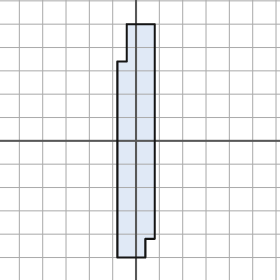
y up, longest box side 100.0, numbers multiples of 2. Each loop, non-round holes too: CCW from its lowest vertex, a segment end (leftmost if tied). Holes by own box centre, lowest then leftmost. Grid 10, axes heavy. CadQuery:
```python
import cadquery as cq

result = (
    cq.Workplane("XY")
    .moveTo(-8.0, -50.0)
    .lineTo(4.0, -50.0)
    .lineTo(4.0, -42.0)
    .lineTo(8.0, -42.0)
    .lineTo(8.0, 50.0)
    .lineTo(-4.0, 50.0)
    .lineTo(-4.0, 34.0)
    .lineTo(-8.0, 34.0)
    .close()
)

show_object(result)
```